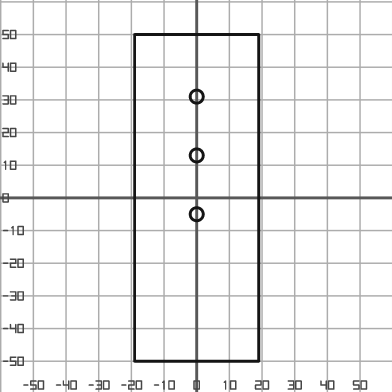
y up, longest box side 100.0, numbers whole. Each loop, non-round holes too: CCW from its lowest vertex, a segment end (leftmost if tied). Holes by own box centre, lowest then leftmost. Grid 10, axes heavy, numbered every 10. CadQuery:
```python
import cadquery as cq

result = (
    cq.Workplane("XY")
    .moveTo(-19.0, -50.0)
    .lineTo(19.0, -50.0)
    .lineTo(19.0, 50.0)
    .lineTo(-19.0, 50.0)
    .close()
    .moveTo(0.0, -5.0)
    .circle(2.0)
    .moveTo(0.0, 13.0)
    .circle(2.0)
    .moveTo(0.0, 31.0)
    .circle(2.0)
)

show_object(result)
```